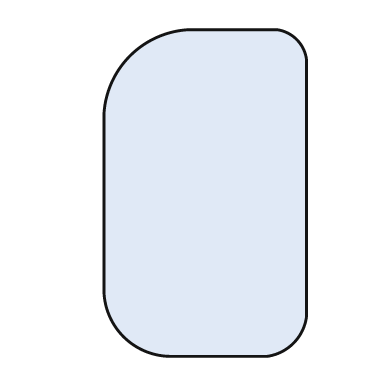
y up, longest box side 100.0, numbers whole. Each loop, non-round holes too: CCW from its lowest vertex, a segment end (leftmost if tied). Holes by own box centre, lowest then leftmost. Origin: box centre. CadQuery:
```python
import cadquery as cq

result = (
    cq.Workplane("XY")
    .moveTo(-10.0, -50.0)
    .lineTo(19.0, -50.0)
    .threePointArc((27.0, -46.0), (31.0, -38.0))
    .lineTo(31.0, 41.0)
    .threePointArc((28.0, 47.0), (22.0, 50.0))
    .lineTo(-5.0, 50.0)
    .threePointArc((-23.0, 42.0), (-31.0, 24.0))
    .lineTo(-31.0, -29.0)
    .threePointArc((-25.0, -44.0), (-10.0, -50.0))
    .close()
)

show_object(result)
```